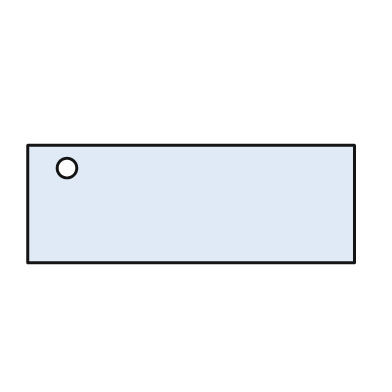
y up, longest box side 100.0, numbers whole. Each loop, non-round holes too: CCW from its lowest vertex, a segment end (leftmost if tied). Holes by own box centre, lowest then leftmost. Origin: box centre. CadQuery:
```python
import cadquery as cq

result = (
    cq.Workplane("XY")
    .moveTo(-50.0, -18.0)
    .lineTo(50.0, -18.0)
    .lineTo(50.0, 18.0)
    .lineTo(-50.0, 18.0)
    .close()
    .moveTo(-38.0, 11.0)
    .circle(3.0)
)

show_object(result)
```